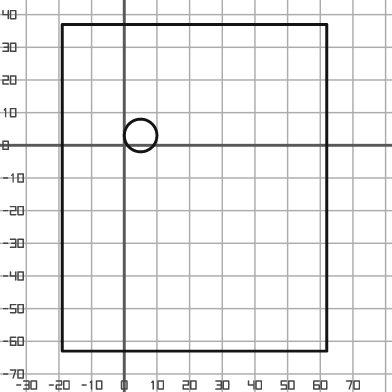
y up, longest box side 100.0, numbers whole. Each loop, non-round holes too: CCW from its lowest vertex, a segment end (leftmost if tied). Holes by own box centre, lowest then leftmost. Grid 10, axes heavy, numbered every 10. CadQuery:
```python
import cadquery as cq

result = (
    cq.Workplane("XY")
    .moveTo(-19.0, -63.0)
    .lineTo(62.0, -63.0)
    .lineTo(62.0, 37.0)
    .lineTo(-19.0, 37.0)
    .close()
    .moveTo(5.0, 3.0)
    .circle(5.0)
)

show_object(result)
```